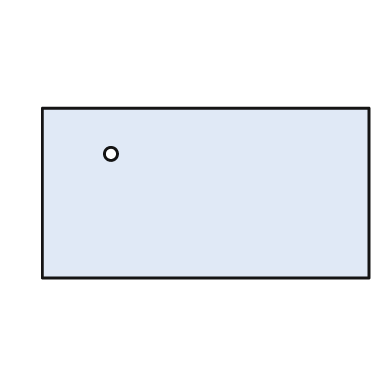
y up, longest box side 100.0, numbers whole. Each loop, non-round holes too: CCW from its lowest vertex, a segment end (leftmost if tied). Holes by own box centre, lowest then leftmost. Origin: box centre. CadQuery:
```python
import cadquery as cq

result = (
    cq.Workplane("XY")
    .moveTo(-50.0, -26.0)
    .lineTo(50.0, -26.0)
    .lineTo(50.0, 26.0)
    .lineTo(-50.0, 26.0)
    .close()
    .moveTo(-29.0, 12.0)
    .circle(2.0)
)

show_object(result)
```